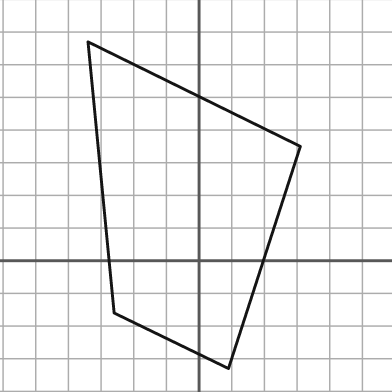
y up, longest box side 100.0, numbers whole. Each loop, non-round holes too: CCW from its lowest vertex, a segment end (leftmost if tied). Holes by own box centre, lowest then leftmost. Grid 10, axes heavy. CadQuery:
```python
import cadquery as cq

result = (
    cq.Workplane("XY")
    .moveTo(9.0, -33.0)
    .lineTo(31.0, 35.0)
    .lineTo(-34.0, 67.0)
    .lineTo(-26.0, -16.0)
    .close()
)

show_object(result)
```